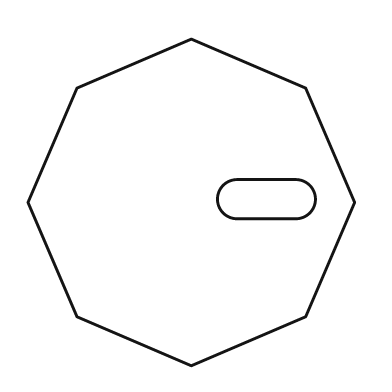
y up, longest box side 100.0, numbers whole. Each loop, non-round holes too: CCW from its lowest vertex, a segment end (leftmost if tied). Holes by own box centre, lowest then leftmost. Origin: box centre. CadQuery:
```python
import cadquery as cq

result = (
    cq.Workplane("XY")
    .moveTo(0.0, -50.0)
    .lineTo(35.0, -35.0)
    .lineTo(50.0, 0.0)
    .lineTo(35.0, 35.0)
    .lineTo(0.0, 50.0)
    .lineTo(-35.0, 35.0)
    .lineTo(-50.0, 0.0)
    .lineTo(-35.0, -35.0)
    .close()
    .moveTo(14.0, -5.0)
    .lineTo(32.0, -5.0)
    .threePointArc((38.0, 1.0), (32.0, 7.0))
    .lineTo(14.0, 7.0)
    .threePointArc((8.0, 1.0), (14.0, -5.0))
    .close()
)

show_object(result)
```